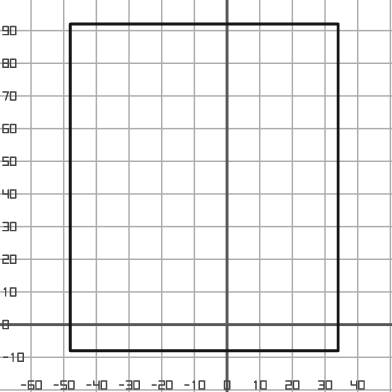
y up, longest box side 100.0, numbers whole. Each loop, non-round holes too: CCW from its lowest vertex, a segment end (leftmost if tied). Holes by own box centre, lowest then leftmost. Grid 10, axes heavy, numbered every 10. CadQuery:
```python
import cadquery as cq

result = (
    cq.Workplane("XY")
    .moveTo(-48.0, -8.0)
    .lineTo(34.0, -8.0)
    .lineTo(34.0, 92.0)
    .lineTo(-48.0, 92.0)
    .close()
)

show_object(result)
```